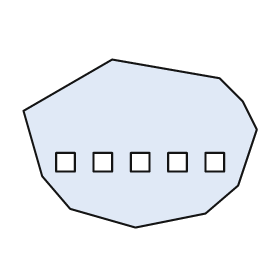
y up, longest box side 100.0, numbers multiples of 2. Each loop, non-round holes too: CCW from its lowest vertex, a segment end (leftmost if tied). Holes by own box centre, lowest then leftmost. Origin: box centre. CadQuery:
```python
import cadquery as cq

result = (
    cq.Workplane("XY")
    .moveTo(-2.0, -36.0)
    .lineTo(28.0, -30.0)
    .lineTo(42.0, -18.0)
    .lineTo(50.0, 6.0)
    .lineTo(44.0, 18.0)
    .lineTo(34.0, 28.0)
    .lineTo(-12.0, 36.0)
    .lineTo(-50.0, 14.0)
    .lineTo(-42.0, -14.0)
    .lineTo(-30.0, -28.0)
    .close()
    .moveTo(-36.0, -12.0)
    .lineTo(-28.0, -12.0)
    .lineTo(-28.0, -4.0)
    .lineTo(-36.0, -4.0)
    .close()
    .moveTo(-20.0, -12.0)
    .lineTo(-12.0, -12.0)
    .lineTo(-12.0, -4.0)
    .lineTo(-20.0, -4.0)
    .close()
    .moveTo(-4.0, -12.0)
    .lineTo(4.0, -12.0)
    .lineTo(4.0, -4.0)
    .lineTo(-4.0, -4.0)
    .close()
    .moveTo(12.0, -12.0)
    .lineTo(20.0, -12.0)
    .lineTo(20.0, -4.0)
    .lineTo(12.0, -4.0)
    .close()
    .moveTo(28.0, -12.0)
    .lineTo(36.0, -12.0)
    .lineTo(36.0, -4.0)
    .lineTo(28.0, -4.0)
    .close()
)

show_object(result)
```